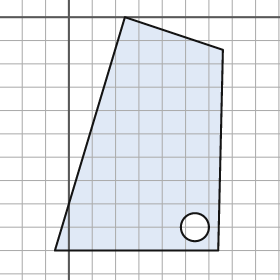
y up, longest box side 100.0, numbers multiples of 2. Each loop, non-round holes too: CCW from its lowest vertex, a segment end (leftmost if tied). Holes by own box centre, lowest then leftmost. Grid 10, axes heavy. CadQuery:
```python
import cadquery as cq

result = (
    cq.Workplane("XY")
    .moveTo(-6.0, -100.0)
    .lineTo(64.0, -100.0)
    .lineTo(66.0, -14.0)
    .lineTo(24.0, 0.0)
    .close()
    .moveTo(54.0, -90.0)
    .circle(6.0)
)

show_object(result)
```